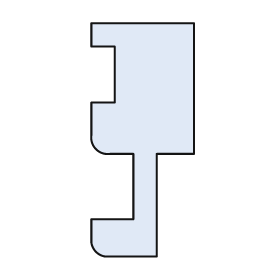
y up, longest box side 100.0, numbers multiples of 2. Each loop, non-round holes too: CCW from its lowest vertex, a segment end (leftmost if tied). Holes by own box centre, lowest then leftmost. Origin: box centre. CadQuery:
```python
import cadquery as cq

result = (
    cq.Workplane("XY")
    .moveTo(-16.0, -50.0)
    .lineTo(6.0, -50.0)
    .lineTo(6.0, -6.0)
    .lineTo(22.0, -6.0)
    .lineTo(22.0, 50.0)
    .lineTo(-22.0, 50.0)
    .lineTo(-22.0, 40.0)
    .lineTo(-12.0, 40.0)
    .lineTo(-12.0, 16.0)
    .lineTo(-22.0, 16.0)
    .lineTo(-22.0, 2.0)
    .threePointArc((-20.0, -4.0), (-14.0, -6.0))
    .lineTo(-4.0, -6.0)
    .lineTo(-4.0, -34.0)
    .lineTo(-22.0, -34.0)
    .lineTo(-22.0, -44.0)
    .threePointArc((-20.0, -48.0), (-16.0, -50.0))
    .close()
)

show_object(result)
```